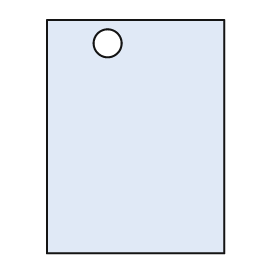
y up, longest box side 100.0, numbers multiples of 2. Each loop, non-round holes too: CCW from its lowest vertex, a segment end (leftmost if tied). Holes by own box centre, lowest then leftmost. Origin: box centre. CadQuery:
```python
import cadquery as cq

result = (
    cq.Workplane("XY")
    .moveTo(-38.0, -50.0)
    .lineTo(38.0, -50.0)
    .lineTo(38.0, 50.0)
    .lineTo(-38.0, 50.0)
    .close()
    .moveTo(-12.0, 40.0)
    .circle(6.0)
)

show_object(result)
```